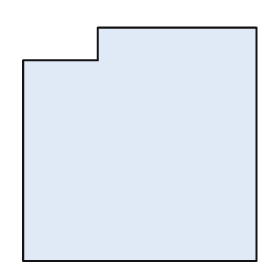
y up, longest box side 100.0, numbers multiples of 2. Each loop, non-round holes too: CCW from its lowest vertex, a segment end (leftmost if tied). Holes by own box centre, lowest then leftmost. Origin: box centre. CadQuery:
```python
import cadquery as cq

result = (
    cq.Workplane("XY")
    .moveTo(-50.0, -50.0)
    .lineTo(50.0, -50.0)
    .lineTo(50.0, 50.0)
    .lineTo(-18.0, 50.0)
    .lineTo(-18.0, 36.0)
    .lineTo(-50.0, 36.0)
    .close()
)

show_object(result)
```